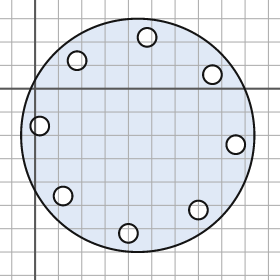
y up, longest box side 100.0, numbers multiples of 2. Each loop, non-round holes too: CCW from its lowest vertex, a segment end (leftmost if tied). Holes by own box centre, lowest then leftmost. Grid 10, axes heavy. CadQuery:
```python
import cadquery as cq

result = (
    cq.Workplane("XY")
    .moveTo(44.0, -20.0)
    .circle(50.0)
    .moveTo(40.0, -62.0)
    .circle(4.0)
    .moveTo(70.0, -52.0)
    .circle(4.0)
    .moveTo(12.0, -46.0)
    .circle(4.0)
    .moveTo(86.0, -24.0)
    .circle(4.0)
    .moveTo(2.0, -16.0)
    .circle(4.0)
    .moveTo(76.0, 6.0)
    .circle(4.0)
    .moveTo(18.0, 12.0)
    .circle(4.0)
    .moveTo(48.0, 22.0)
    .circle(4.0)
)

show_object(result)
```